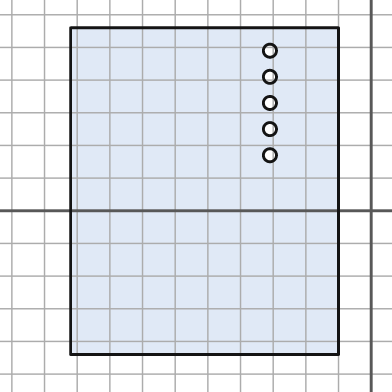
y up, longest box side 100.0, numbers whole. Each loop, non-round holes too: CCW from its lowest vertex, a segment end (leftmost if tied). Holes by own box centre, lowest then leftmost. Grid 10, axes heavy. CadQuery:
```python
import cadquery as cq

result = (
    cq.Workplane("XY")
    .moveTo(-92.0, -44.0)
    .lineTo(-10.0, -44.0)
    .lineTo(-10.0, 56.0)
    .lineTo(-92.0, 56.0)
    .close()
    .moveTo(-31.0, 17.0)
    .circle(2.0)
    .moveTo(-31.0, 25.0)
    .circle(2.0)
    .moveTo(-31.0, 33.0)
    .circle(2.0)
    .moveTo(-31.0, 41.0)
    .circle(2.0)
    .moveTo(-31.0, 49.0)
    .circle(2.0)
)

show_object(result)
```